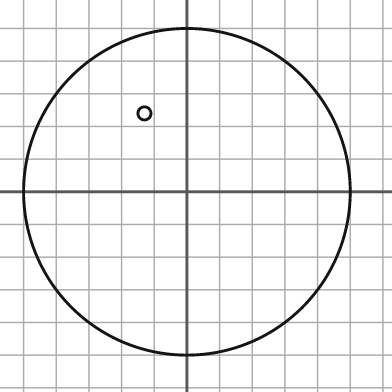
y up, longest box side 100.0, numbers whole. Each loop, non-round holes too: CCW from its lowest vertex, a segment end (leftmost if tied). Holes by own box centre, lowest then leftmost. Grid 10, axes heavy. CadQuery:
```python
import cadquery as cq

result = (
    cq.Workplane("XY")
    .moveTo(0.0, 0.0)
    .circle(50.0)
    .moveTo(-13.0, 24.0)
    .circle(2.0)
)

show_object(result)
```